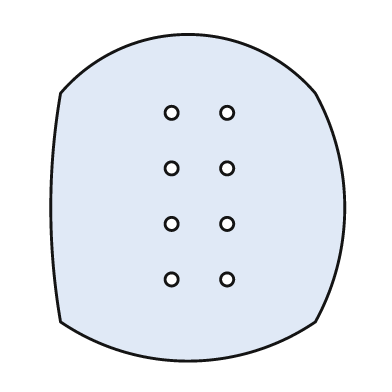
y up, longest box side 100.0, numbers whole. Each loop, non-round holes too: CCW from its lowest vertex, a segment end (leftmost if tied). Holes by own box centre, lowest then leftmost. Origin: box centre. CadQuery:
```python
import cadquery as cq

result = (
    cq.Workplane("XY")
    .moveTo(-42.0, -38.0)
    .threePointArc((-3.0, -50.0), (36.0, -38.0))
    .threePointArc((45.0, -3.0), (36.0, 32.0))
    .threePointArc((-3.0, 50.0), (-42.0, 32.0))
    .threePointArc((-45.0, -3.0), (-42.0, -38.0))
    .close()
    .moveTo(-8.0, -25.0)
    .circle(2.0)
    .moveTo(9.0, -25.0)
    .circle(2.0)
    .moveTo(-8.0, -8.0)
    .circle(2.0)
    .moveTo(9.0, -8.0)
    .circle(2.0)
    .moveTo(-8.0, 9.0)
    .circle(2.0)
    .moveTo(9.0, 9.0)
    .circle(2.0)
    .moveTo(-8.0, 26.0)
    .circle(2.0)
    .moveTo(9.0, 26.0)
    .circle(2.0)
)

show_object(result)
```